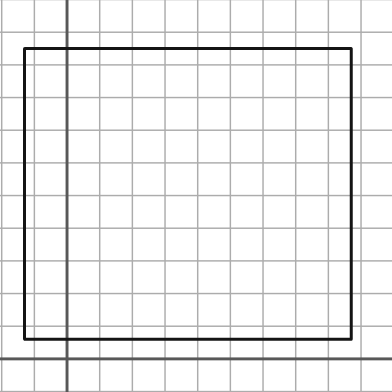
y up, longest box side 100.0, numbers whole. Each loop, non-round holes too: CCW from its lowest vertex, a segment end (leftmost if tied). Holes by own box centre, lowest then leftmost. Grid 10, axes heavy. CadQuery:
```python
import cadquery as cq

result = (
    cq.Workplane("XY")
    .moveTo(-13.0, 6.0)
    .lineTo(87.0, 6.0)
    .lineTo(87.0, 95.0)
    .lineTo(-13.0, 95.0)
    .close()
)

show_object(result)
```